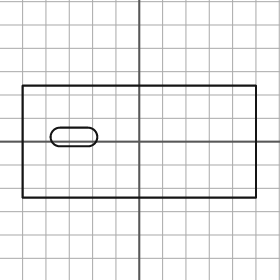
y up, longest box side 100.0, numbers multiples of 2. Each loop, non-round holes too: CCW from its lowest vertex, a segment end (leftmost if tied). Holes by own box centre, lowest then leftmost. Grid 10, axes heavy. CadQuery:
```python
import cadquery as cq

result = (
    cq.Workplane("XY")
    .moveTo(-50.0, -24.0)
    .lineTo(50.0, -24.0)
    .lineTo(50.0, 24.0)
    .lineTo(-50.0, 24.0)
    .close()
    .moveTo(-34.0, -2.0)
    .lineTo(-22.0, -2.0)
    .threePointArc((-18.0, 2.0), (-22.0, 6.0))
    .lineTo(-34.0, 6.0)
    .threePointArc((-38.0, 2.0), (-34.0, -2.0))
    .close()
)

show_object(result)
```